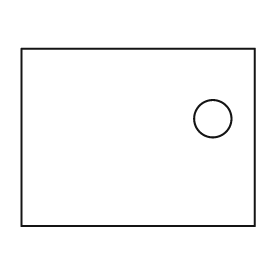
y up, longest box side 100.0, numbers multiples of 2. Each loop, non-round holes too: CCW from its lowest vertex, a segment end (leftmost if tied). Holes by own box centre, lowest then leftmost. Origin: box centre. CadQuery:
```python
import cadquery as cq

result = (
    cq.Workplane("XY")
    .moveTo(-50.0, -38.0)
    .lineTo(50.0, -38.0)
    .lineTo(50.0, 38.0)
    .lineTo(-50.0, 38.0)
    .close()
    .moveTo(32.0, 8.0)
    .circle(8.0)
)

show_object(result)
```